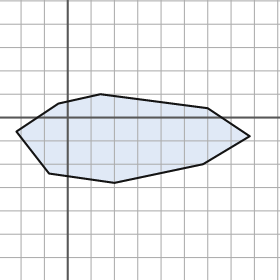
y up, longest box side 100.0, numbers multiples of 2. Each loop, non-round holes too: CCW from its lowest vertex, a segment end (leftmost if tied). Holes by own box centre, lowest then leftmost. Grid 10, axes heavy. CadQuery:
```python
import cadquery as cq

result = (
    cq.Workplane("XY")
    .moveTo(20.0, -28.0)
    .lineTo(58.0, -20.0)
    .lineTo(78.0, -8.0)
    .lineTo(60.0, 4.0)
    .lineTo(14.0, 10.0)
    .lineTo(-4.0, 6.0)
    .lineTo(-22.0, -6.0)
    .lineTo(-8.0, -24.0)
    .close()
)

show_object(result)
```